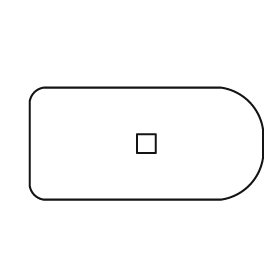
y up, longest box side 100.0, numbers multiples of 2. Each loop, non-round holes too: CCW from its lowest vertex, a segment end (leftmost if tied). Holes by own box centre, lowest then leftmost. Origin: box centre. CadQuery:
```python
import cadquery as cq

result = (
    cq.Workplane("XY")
    .moveTo(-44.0, -24.0)
    .lineTo(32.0, -24.0)
    .threePointArc((44.0, -18.0), (50.0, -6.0))
    .lineTo(50.0, 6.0)
    .threePointArc((44.0, 18.0), (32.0, 24.0))
    .lineTo(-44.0, 24.0)
    .threePointArc((-48.0, 22.0), (-50.0, 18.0))
    .lineTo(-50.0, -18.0)
    .threePointArc((-48.0, -22.0), (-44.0, -24.0))
    .close()
    .moveTo(-4.0, -4.0)
    .lineTo(4.0, -4.0)
    .lineTo(4.0, 4.0)
    .lineTo(-4.0, 4.0)
    .close()
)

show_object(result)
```